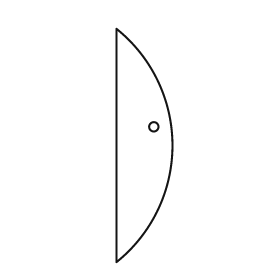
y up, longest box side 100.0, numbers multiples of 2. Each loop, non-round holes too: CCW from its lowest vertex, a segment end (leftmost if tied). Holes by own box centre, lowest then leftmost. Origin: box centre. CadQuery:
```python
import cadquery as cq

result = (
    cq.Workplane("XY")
    .moveTo(-12.0, -50.0)
    .threePointArc((12.0, 0.0), (-12.0, 50.0))
    .close()
    .moveTo(4.0, 8.0)
    .circle(2.0)
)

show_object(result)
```